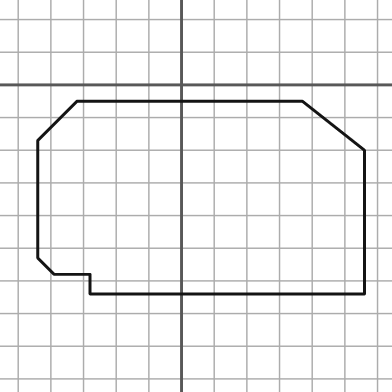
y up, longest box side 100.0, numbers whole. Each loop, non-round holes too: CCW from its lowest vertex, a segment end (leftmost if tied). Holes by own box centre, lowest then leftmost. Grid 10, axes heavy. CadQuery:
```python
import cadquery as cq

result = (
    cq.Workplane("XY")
    .moveTo(-28.0, -64.0)
    .lineTo(56.0, -64.0)
    .lineTo(56.0, -20.0)
    .lineTo(37.0, -5.0)
    .lineTo(-32.0, -5.0)
    .lineTo(-44.0, -17.0)
    .lineTo(-44.0, -53.0)
    .lineTo(-39.0, -58.0)
    .lineTo(-28.0, -58.0)
    .close()
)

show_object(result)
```